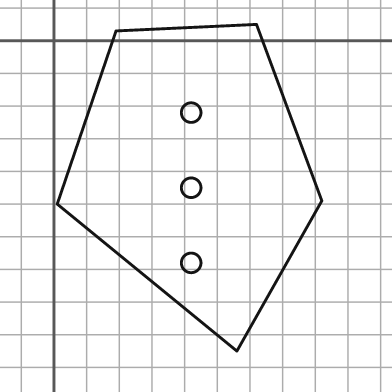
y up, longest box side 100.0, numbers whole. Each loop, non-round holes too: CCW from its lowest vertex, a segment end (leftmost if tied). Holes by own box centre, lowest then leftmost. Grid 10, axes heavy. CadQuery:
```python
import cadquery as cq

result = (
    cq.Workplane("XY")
    .moveTo(56.0, -95.0)
    .lineTo(82.0, -49.0)
    .lineTo(62.0, 5.0)
    .lineTo(19.0, 3.0)
    .lineTo(1.0, -50.0)
    .close()
    .moveTo(42.0, -68.0)
    .circle(3.0)
    .moveTo(42.0, -45.0)
    .circle(3.0)
    .moveTo(42.0, -22.0)
    .circle(3.0)
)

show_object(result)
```